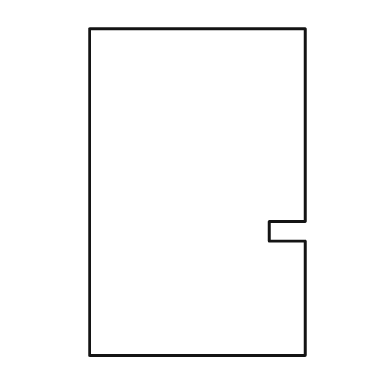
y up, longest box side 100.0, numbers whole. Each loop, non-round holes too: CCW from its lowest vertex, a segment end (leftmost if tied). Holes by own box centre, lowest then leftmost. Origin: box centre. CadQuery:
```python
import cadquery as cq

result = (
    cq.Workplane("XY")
    .moveTo(-33.0, -50.0)
    .lineTo(33.0, -50.0)
    .lineTo(33.0, -15.0)
    .lineTo(22.0, -15.0)
    .lineTo(22.0, -9.0)
    .lineTo(33.0, -9.0)
    .lineTo(33.0, 50.0)
    .lineTo(-33.0, 50.0)
    .close()
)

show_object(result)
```